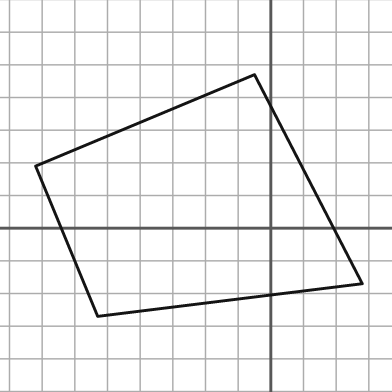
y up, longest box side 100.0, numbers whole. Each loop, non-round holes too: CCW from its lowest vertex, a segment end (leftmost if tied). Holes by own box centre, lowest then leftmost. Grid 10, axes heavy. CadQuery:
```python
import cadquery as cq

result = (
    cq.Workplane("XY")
    .moveTo(-53.0, -27.0)
    .lineTo(28.0, -17.0)
    .lineTo(-5.0, 47.0)
    .lineTo(-72.0, 19.0)
    .close()
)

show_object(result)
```